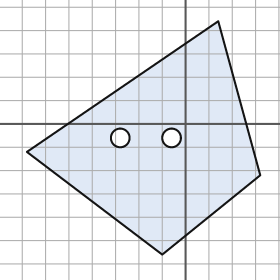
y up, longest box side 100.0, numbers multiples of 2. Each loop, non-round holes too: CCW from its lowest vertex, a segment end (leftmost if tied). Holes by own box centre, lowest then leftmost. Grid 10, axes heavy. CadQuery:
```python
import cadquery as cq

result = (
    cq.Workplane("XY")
    .moveTo(-10.0, -56.0)
    .lineTo(32.0, -22.0)
    .lineTo(14.0, 44.0)
    .lineTo(-68.0, -12.0)
    .close()
    .moveTo(-28.0, -6.0)
    .circle(4.0)
    .moveTo(-6.0, -6.0)
    .circle(4.0)
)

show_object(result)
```